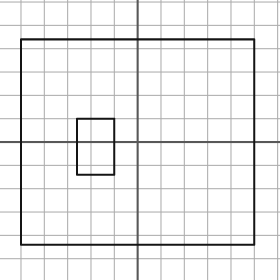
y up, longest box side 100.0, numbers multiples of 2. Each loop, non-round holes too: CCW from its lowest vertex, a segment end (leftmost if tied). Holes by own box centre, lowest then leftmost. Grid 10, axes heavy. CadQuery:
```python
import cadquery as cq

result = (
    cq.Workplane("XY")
    .moveTo(-50.0, -44.0)
    .lineTo(50.0, -44.0)
    .lineTo(50.0, 44.0)
    .lineTo(-50.0, 44.0)
    .close()
    .moveTo(-26.0, -14.0)
    .lineTo(-10.0, -14.0)
    .lineTo(-10.0, 10.0)
    .lineTo(-26.0, 10.0)
    .close()
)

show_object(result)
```